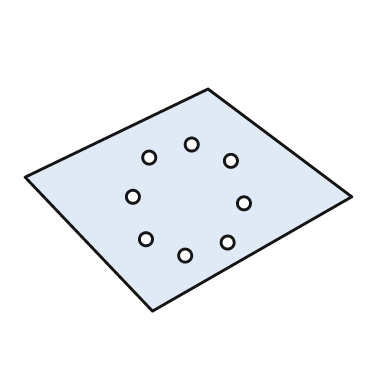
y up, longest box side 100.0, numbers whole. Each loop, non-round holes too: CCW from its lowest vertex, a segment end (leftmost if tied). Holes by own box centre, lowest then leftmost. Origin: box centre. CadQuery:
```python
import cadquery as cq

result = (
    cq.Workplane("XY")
    .moveTo(-11.0, -34.0)
    .lineTo(50.0, 1.0)
    .lineTo(6.0, 34.0)
    .lineTo(-50.0, 7.0)
    .close()
    .moveTo(-1.0, -17.0)
    .circle(2.0)
    .moveTo(12.0, -13.0)
    .circle(2.0)
    .moveTo(-13.0, -12.0)
    .circle(2.0)
    .moveTo(17.0, -1.0)
    .circle(2.0)
    .moveTo(-17.0, 1.0)
    .circle(2.0)
    .moveTo(13.0, 12.0)
    .circle(2.0)
    .moveTo(-12.0, 13.0)
    .circle(2.0)
    .moveTo(1.0, 17.0)
    .circle(2.0)
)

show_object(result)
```